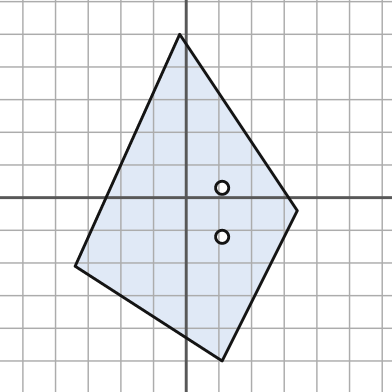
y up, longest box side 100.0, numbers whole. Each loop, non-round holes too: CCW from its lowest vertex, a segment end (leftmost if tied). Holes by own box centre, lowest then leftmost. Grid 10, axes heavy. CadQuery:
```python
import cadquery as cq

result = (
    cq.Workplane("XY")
    .moveTo(11.0, -50.0)
    .lineTo(34.0, -4.0)
    .lineTo(-2.0, 50.0)
    .lineTo(-34.0, -21.0)
    .close()
    .moveTo(11.0, -12.0)
    .circle(2.0)
    .moveTo(11.0, 3.0)
    .circle(2.0)
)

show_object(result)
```